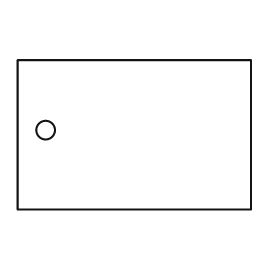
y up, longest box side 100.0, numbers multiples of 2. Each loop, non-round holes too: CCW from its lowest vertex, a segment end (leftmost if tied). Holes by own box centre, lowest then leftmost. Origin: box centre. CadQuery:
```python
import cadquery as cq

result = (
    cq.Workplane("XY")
    .moveTo(-50.0, -32.0)
    .lineTo(50.0, -32.0)
    .lineTo(50.0, 32.0)
    .lineTo(-50.0, 32.0)
    .close()
    .moveTo(-38.0, 2.0)
    .circle(4.0)
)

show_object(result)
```